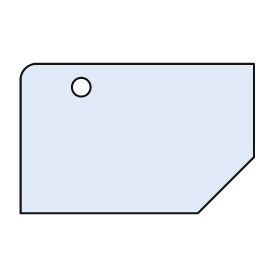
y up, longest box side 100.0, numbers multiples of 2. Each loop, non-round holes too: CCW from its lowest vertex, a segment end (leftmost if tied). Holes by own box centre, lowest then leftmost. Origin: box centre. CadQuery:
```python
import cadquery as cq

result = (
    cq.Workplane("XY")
    .moveTo(-50.0, -32.0)
    .lineTo(26.0, -32.0)
    .lineTo(50.0, -8.0)
    .lineTo(50.0, 32.0)
    .lineTo(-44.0, 32.0)
    .threePointArc((-48.0, 30.0), (-50.0, 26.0))
    .close()
    .moveTo(-24.0, 22.0)
    .circle(4.0)
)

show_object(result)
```